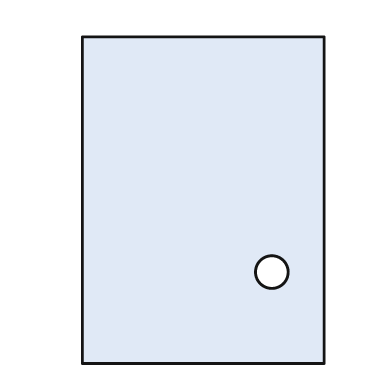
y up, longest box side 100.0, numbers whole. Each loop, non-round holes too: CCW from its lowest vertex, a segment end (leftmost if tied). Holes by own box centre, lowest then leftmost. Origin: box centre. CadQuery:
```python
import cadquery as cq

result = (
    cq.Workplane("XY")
    .moveTo(-37.0, -50.0)
    .lineTo(37.0, -50.0)
    .lineTo(37.0, 50.0)
    .lineTo(-37.0, 50.0)
    .close()
    .moveTo(21.0, -22.0)
    .circle(5.0)
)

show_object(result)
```